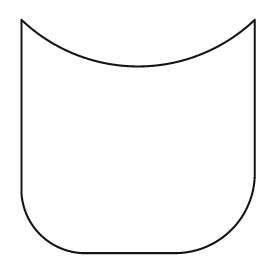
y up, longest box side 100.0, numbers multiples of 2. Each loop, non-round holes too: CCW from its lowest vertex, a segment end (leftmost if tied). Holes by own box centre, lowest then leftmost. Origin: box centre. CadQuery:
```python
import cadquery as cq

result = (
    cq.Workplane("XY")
    .moveTo(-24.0, -50.0)
    .lineTo(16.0, -50.0)
    .threePointArc((40.0, -40.0), (50.0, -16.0))
    .lineTo(50.0, 50.0)
    .threePointArc((0.0, 30.0), (-50.0, 50.0))
    .lineTo(-50.0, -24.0)
    .threePointArc((-42.0, -42.0), (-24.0, -50.0))
    .close()
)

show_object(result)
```